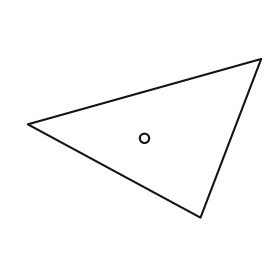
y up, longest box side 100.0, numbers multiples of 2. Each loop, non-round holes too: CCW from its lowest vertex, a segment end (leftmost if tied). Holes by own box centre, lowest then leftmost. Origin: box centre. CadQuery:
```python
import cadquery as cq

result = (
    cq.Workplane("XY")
    .moveTo(24.0, -34.0)
    .lineTo(50.0, 34.0)
    .lineTo(-50.0, 6.0)
    .close()
    .moveTo(0.0, 0.0)
    .circle(2.0)
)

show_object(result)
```